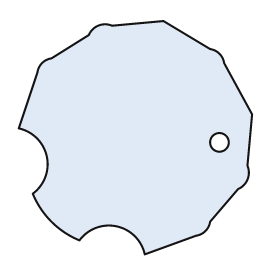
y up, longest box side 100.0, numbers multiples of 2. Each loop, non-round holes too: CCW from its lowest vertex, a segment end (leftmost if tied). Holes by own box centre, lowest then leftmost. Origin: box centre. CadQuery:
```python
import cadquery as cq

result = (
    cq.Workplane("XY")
    .moveTo(4.0, -50.0)
    .lineTo(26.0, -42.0)
    .threePointArc((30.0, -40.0), (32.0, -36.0))
    .lineTo(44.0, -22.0)
    .threePointArc((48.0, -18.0), (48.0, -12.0))
    .lineTo(50.0, 10.0)
    .lineTo(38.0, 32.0)
    .threePointArc((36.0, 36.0), (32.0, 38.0))
    .lineTo(12.0, 50.0)
    .lineTo(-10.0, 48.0)
    .threePointArc((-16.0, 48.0), (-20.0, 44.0))
    .lineTo(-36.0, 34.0)
    .threePointArc((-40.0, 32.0), (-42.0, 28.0))
    .lineTo(-50.0, 4.0)
    .threePointArc((-38.0, -8.0), (-44.0, -24.0))
    .threePointArc((-36.0, -36.0), (-24.0, -44.0))
    .threePointArc((-8.0, -38.0), (4.0, -50.0))
    .close()
    .moveTo(36.0, -2.0)
    .circle(4.0)
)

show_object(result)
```